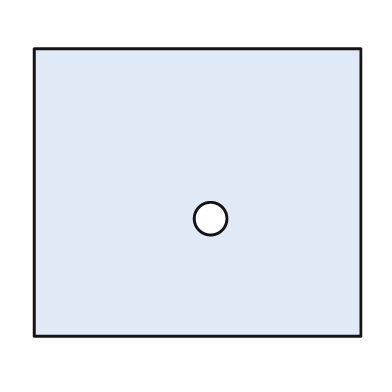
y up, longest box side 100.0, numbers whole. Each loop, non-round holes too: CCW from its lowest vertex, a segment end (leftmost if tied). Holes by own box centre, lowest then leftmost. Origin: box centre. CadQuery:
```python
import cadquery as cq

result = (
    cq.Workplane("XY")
    .moveTo(-50.0, -44.0)
    .lineTo(50.0, -44.0)
    .lineTo(50.0, 44.0)
    .lineTo(-50.0, 44.0)
    .close()
    .moveTo(4.0, -8.0)
    .circle(5.0)
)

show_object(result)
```